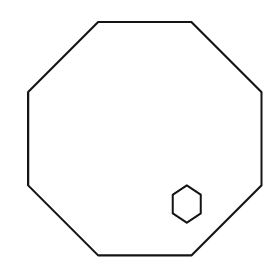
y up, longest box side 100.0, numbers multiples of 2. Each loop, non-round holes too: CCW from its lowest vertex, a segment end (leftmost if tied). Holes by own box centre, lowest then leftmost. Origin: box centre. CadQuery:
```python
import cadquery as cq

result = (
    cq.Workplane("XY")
    .moveTo(-20.0, -50.0)
    .lineTo(20.0, -50.0)
    .lineTo(50.0, -20.0)
    .lineTo(50.0, 20.0)
    .lineTo(20.0, 50.0)
    .lineTo(-20.0, 50.0)
    .lineTo(-50.0, 20.0)
    .lineTo(-50.0, -20.0)
    .close()
    .moveTo(18.0, -36.0)
    .lineTo(24.0, -32.0)
    .lineTo(24.0, -24.0)
    .lineTo(18.0, -20.0)
    .lineTo(12.0, -24.0)
    .lineTo(12.0, -32.0)
    .close()
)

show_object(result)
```